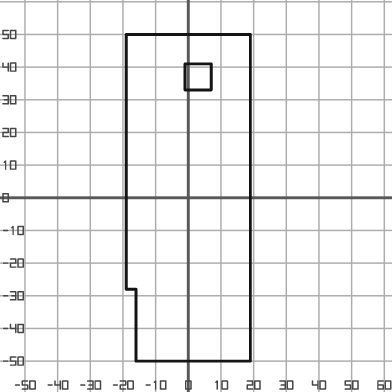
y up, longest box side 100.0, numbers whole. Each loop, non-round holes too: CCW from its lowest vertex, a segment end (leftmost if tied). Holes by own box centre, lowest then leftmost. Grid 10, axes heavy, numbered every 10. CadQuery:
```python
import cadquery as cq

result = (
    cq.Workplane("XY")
    .moveTo(-16.0, -50.0)
    .lineTo(19.0, -50.0)
    .lineTo(19.0, 50.0)
    .lineTo(-19.0, 50.0)
    .lineTo(-19.0, -28.0)
    .lineTo(-16.0, -28.0)
    .close()
    .moveTo(-1.0, 33.0)
    .lineTo(7.0, 33.0)
    .lineTo(7.0, 41.0)
    .lineTo(-1.0, 41.0)
    .close()
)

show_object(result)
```